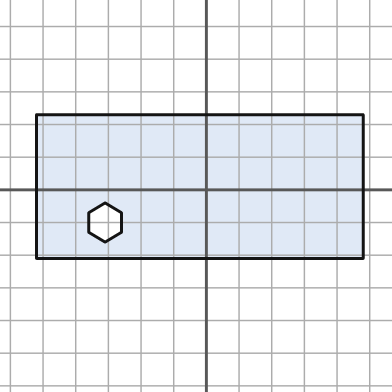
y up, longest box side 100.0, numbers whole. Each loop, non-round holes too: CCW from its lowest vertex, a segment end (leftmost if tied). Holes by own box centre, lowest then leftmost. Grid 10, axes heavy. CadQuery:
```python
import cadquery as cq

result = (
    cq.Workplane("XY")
    .moveTo(-52.0, -21.0)
    .lineTo(48.0, -21.0)
    .lineTo(48.0, 23.0)
    .lineTo(-52.0, 23.0)
    .close()
    .moveTo(-31.0, -16.0)
    .lineTo(-26.0, -13.0)
    .lineTo(-26.0, -7.0)
    .lineTo(-31.0, -4.0)
    .lineTo(-36.0, -7.0)
    .lineTo(-36.0, -13.0)
    .close()
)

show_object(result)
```